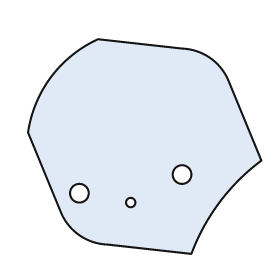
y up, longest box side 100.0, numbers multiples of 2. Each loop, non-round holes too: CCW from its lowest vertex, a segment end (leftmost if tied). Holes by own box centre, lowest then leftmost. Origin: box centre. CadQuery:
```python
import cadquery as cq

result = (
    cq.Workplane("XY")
    .moveTo(20.0, -46.0)
    .threePointArc((32.0, -24.0), (50.0, -6.0))
    .lineTo(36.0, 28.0)
    .threePointArc((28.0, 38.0), (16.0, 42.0))
    .lineTo(-20.0, 46.0)
    .threePointArc((-40.0, 30.0), (-50.0, 6.0))
    .lineTo(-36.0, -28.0)
    .threePointArc((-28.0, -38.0), (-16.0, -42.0))
    .close()
    .moveTo(-6.0, -24.0)
    .circle(2.0)
    .moveTo(-28.0, -20.0)
    .circle(4.0)
    .moveTo(16.0, -12.0)
    .circle(4.0)
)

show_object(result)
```